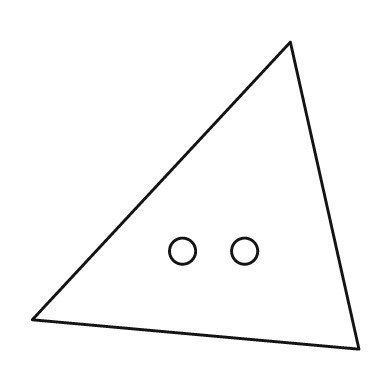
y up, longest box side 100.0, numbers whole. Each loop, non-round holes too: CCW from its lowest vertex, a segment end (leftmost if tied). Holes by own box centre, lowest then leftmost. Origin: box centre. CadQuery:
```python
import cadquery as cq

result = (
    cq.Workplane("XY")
    .moveTo(50.0, -47.0)
    .lineTo(29.0, 47.0)
    .lineTo(-50.0, -38.0)
    .close()
    .moveTo(-4.0, -17.0)
    .circle(4.0)
    .moveTo(15.0, -17.0)
    .circle(4.0)
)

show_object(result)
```